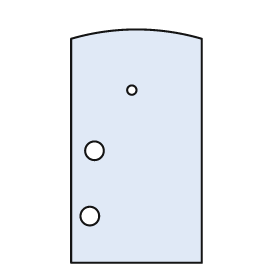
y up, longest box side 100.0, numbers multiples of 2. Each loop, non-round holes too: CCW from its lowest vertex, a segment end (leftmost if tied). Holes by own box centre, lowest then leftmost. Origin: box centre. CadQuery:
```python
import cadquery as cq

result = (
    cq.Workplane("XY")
    .moveTo(-28.0, -50.0)
    .lineTo(28.0, -50.0)
    .lineTo(28.0, 46.0)
    .threePointArc((0.0, 50.0), (-28.0, 46.0))
    .close()
    .moveTo(-20.0, -30.0)
    .circle(4.0)
    .moveTo(-18.0, -2.0)
    .circle(4.0)
    .moveTo(-2.0, 24.0)
    .circle(2.0)
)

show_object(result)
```